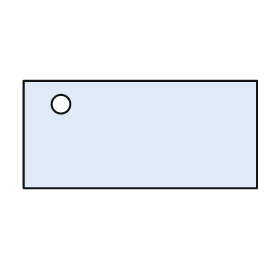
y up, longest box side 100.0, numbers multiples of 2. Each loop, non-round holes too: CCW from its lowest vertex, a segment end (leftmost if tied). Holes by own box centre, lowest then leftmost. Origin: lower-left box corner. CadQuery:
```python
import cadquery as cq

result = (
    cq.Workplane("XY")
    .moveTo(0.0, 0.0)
    .lineTo(100.0, 0.0)
    .lineTo(100.0, 46.0)
    .lineTo(0.0, 46.0)
    .close()
    .moveTo(16.0, 36.0)
    .circle(4.0)
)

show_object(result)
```